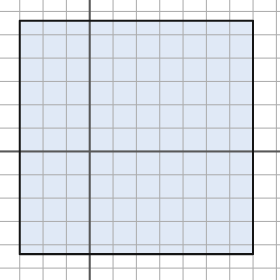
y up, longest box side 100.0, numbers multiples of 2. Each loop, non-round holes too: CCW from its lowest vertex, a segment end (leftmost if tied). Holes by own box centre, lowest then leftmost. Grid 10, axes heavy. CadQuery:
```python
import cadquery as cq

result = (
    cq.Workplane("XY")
    .moveTo(-30.0, -44.0)
    .lineTo(70.0, -44.0)
    .lineTo(70.0, 56.0)
    .lineTo(-30.0, 56.0)
    .close()
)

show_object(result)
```